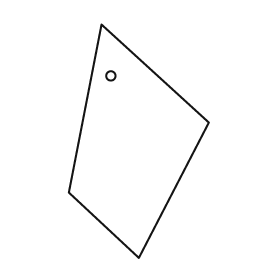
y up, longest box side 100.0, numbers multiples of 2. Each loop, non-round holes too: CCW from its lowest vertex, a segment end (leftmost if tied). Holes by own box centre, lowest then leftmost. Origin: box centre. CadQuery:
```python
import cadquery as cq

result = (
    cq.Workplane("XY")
    .moveTo(0.0, -50.0)
    .lineTo(30.0, 8.0)
    .lineTo(-16.0, 50.0)
    .lineTo(-30.0, -22.0)
    .close()
    .moveTo(-12.0, 28.0)
    .circle(2.0)
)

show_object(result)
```